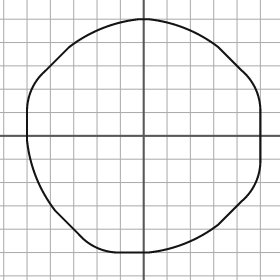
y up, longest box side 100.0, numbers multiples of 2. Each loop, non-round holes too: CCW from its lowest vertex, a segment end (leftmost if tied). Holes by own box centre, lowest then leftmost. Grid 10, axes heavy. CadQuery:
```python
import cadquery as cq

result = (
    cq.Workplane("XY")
    .moveTo(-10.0, -50.0)
    .lineTo(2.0, -50.0)
    .threePointArc((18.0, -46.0), (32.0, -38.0))
    .lineTo(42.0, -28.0)
    .threePointArc((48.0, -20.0), (50.0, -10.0))
    .lineTo(50.0, 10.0)
    .threePointArc((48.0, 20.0), (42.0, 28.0))
    .lineTo(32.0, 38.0)
    .threePointArc((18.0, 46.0), (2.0, 50.0))
    .lineTo(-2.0, 50.0)
    .threePointArc((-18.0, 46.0), (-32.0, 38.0))
    .lineTo(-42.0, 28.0)
    .threePointArc((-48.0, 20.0), (-50.0, 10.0))
    .lineTo(-50.0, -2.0)
    .threePointArc((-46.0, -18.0), (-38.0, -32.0))
    .lineTo(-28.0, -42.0)
    .threePointArc((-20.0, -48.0), (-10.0, -50.0))
    .close()
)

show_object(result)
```